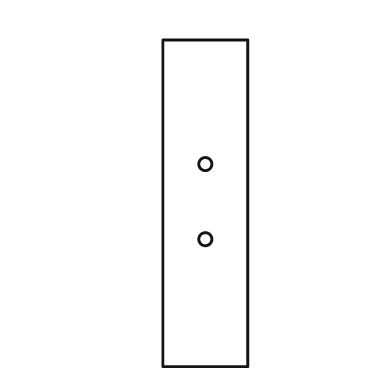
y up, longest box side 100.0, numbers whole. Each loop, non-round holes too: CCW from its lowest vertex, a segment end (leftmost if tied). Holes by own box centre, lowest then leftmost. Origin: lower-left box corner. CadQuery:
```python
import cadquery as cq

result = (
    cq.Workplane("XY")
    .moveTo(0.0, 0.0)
    .lineTo(26.0, 0.0)
    .lineTo(26.0, 100.0)
    .lineTo(0.0, 100.0)
    .close()
    .moveTo(13.0, 39.0)
    .circle(2.0)
    .moveTo(13.0, 62.0)
    .circle(2.0)
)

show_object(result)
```